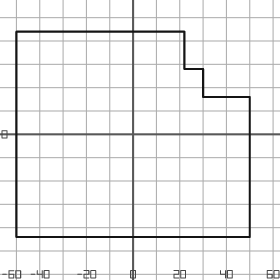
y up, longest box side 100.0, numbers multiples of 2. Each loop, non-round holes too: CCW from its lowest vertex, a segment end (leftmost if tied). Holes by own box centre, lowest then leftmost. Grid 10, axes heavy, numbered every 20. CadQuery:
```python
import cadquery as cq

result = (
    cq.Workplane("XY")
    .moveTo(-50.0, -44.0)
    .lineTo(50.0, -44.0)
    .lineTo(50.0, 16.0)
    .lineTo(30.0, 16.0)
    .lineTo(30.0, 28.0)
    .lineTo(22.0, 28.0)
    .lineTo(22.0, 44.0)
    .lineTo(-50.0, 44.0)
    .close()
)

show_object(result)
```